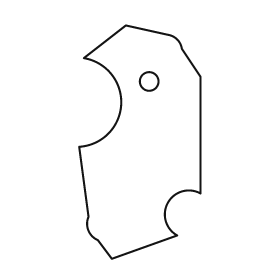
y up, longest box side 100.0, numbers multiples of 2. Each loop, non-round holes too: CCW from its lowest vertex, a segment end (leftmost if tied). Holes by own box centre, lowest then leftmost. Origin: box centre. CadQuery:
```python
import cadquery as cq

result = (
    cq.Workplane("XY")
    .moveTo(-12.0, -50.0)
    .lineTo(16.0, -40.0)
    .threePointArc((12.0, -26.0), (26.0, -22.0))
    .lineTo(26.0, 28.0)
    .lineTo(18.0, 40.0)
    .threePointArc((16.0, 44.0), (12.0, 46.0))
    .lineTo(-6.0, 50.0)
    .lineTo(-24.0, 36.0)
    .threePointArc((-8.0, 16.0), (-26.0, -2.0))
    .lineTo(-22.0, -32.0)
    .threePointArc((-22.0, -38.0), (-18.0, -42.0))
    .close()
    .moveTo(4.0, 26.0)
    .circle(4.0)
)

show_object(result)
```